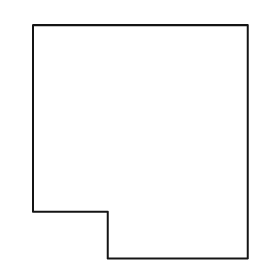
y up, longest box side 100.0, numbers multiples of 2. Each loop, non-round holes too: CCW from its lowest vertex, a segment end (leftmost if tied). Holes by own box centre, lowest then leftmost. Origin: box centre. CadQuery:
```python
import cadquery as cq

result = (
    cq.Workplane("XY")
    .moveTo(-14.0, -50.0)
    .lineTo(46.0, -50.0)
    .lineTo(46.0, 50.0)
    .lineTo(-46.0, 50.0)
    .lineTo(-46.0, -30.0)
    .lineTo(-14.0, -30.0)
    .close()
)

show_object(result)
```